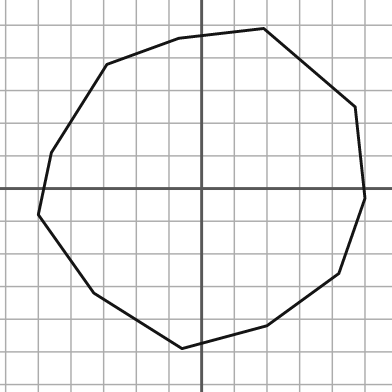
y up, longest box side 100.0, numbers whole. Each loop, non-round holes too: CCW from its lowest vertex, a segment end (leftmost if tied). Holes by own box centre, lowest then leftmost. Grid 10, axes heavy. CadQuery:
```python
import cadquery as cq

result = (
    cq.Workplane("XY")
    .moveTo(-6.0, -49.0)
    .lineTo(20.0, -42.0)
    .lineTo(42.0, -26.0)
    .lineTo(50.0, -3.0)
    .lineTo(47.0, 25.0)
    .lineTo(19.0, 49.0)
    .lineTo(-7.0, 46.0)
    .lineTo(-29.0, 38.0)
    .lineTo(-46.0, 11.0)
    .lineTo(-50.0, -8.0)
    .lineTo(-33.0, -32.0)
    .close()
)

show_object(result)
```